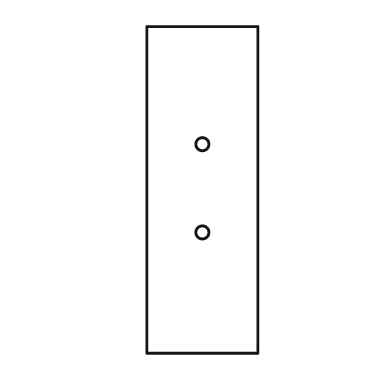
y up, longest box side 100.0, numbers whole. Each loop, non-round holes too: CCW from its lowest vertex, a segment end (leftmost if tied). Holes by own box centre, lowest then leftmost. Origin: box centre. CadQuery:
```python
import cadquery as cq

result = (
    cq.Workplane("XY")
    .moveTo(-17.0, -50.0)
    .lineTo(17.0, -50.0)
    .lineTo(17.0, 50.0)
    .lineTo(-17.0, 50.0)
    .close()
    .moveTo(0.0, -13.0)
    .circle(2.0)
    .moveTo(0.0, 14.0)
    .circle(2.0)
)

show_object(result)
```